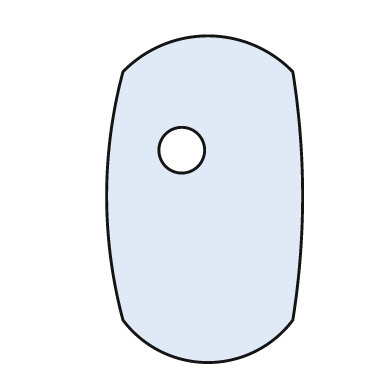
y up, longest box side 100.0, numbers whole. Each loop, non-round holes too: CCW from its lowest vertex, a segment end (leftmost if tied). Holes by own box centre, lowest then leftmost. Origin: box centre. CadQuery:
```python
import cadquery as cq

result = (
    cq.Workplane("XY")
    .moveTo(-25.0, -37.0)
    .threePointArc((1.0, -50.0), (27.0, -37.0))
    .threePointArc((30.0, 1.0), (27.0, 39.0))
    .threePointArc((1.0, 50.0), (-25.0, 39.0))
    .threePointArc((-30.0, 1.0), (-25.0, -37.0))
    .close()
    .moveTo(-7.0, 15.0)
    .circle(7.0)
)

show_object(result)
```